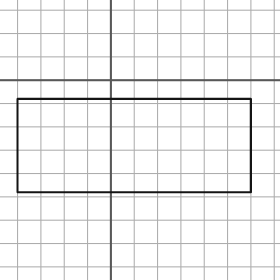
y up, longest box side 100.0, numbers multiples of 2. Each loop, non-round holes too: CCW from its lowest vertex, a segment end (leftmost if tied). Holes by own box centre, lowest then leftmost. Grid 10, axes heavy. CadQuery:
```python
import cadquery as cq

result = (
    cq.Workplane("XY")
    .moveTo(-40.0, -48.0)
    .lineTo(60.0, -48.0)
    .lineTo(60.0, -8.0)
    .lineTo(-40.0, -8.0)
    .close()
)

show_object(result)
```